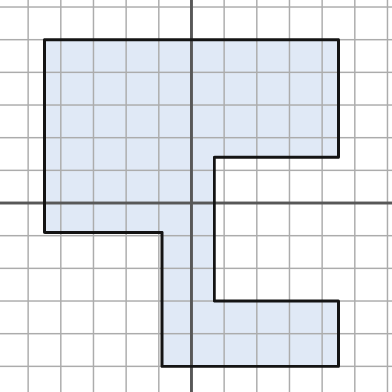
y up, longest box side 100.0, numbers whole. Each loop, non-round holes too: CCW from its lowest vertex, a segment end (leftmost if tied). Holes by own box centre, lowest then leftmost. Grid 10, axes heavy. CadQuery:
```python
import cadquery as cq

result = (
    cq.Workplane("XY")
    .moveTo(-9.0, -50.0)
    .lineTo(45.0, -50.0)
    .lineTo(45.0, -30.0)
    .lineTo(7.0, -30.0)
    .lineTo(7.0, 14.0)
    .lineTo(45.0, 14.0)
    .lineTo(45.0, 50.0)
    .lineTo(-45.0, 50.0)
    .lineTo(-45.0, -9.0)
    .lineTo(-9.0, -9.0)
    .close()
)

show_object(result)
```